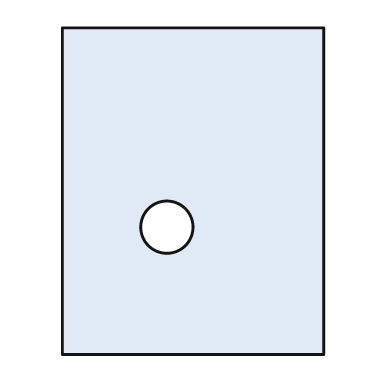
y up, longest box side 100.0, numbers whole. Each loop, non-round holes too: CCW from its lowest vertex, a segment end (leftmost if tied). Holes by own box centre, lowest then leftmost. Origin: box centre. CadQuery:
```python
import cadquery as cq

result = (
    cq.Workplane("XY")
    .moveTo(-40.0, -50.0)
    .lineTo(40.0, -50.0)
    .lineTo(40.0, 50.0)
    .lineTo(-40.0, 50.0)
    .close()
    .moveTo(-8.0, -11.0)
    .circle(8.0)
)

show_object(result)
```